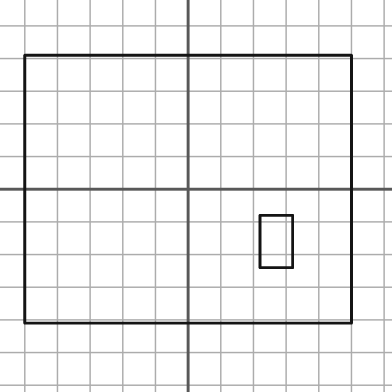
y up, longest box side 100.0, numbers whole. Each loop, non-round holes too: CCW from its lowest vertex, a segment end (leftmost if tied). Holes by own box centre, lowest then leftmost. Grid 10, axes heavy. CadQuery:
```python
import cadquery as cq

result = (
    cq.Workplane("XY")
    .moveTo(-50.0, -41.0)
    .lineTo(50.0, -41.0)
    .lineTo(50.0, 41.0)
    .lineTo(-50.0, 41.0)
    .close()
    .moveTo(22.0, -24.0)
    .lineTo(32.0, -24.0)
    .lineTo(32.0, -8.0)
    .lineTo(22.0, -8.0)
    .close()
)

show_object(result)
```